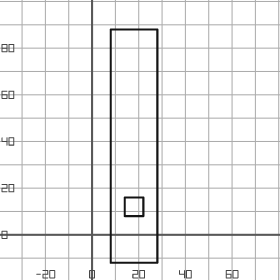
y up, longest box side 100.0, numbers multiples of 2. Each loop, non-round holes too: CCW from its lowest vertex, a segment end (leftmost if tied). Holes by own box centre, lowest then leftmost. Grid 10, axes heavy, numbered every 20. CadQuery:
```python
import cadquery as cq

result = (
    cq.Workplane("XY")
    .moveTo(8.0, -12.0)
    .lineTo(28.0, -12.0)
    .lineTo(28.0, 88.0)
    .lineTo(8.0, 88.0)
    .close()
    .moveTo(14.0, 8.0)
    .lineTo(22.0, 8.0)
    .lineTo(22.0, 16.0)
    .lineTo(14.0, 16.0)
    .close()
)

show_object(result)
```